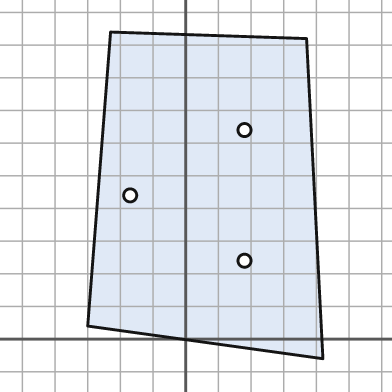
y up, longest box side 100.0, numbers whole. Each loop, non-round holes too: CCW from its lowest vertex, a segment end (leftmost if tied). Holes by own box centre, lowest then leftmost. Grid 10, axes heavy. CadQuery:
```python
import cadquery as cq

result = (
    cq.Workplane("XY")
    .moveTo(42.0, -6.0)
    .lineTo(37.0, 92.0)
    .lineTo(-23.0, 94.0)
    .lineTo(-30.0, 4.0)
    .close()
    .moveTo(18.0, 24.0)
    .circle(2.0)
    .moveTo(-17.0, 44.0)
    .circle(2.0)
    .moveTo(18.0, 64.0)
    .circle(2.0)
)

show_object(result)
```